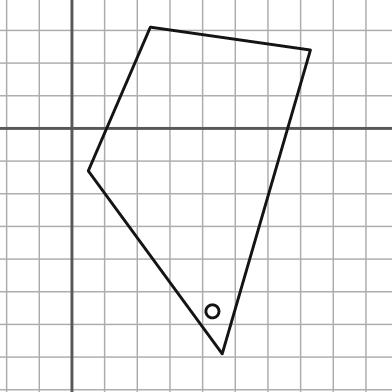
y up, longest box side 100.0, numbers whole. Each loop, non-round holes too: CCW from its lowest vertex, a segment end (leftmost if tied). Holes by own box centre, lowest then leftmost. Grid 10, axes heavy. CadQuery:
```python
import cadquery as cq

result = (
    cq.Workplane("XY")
    .moveTo(46.0, -69.0)
    .lineTo(73.0, 24.0)
    .lineTo(24.0, 31.0)
    .lineTo(5.0, -13.0)
    .close()
    .moveTo(43.0, -56.0)
    .circle(2.0)
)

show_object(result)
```